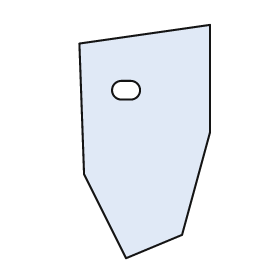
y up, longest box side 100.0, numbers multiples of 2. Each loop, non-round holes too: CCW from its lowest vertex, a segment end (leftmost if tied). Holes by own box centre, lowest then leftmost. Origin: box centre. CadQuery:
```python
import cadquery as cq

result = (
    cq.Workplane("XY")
    .moveTo(-8.0, -50.0)
    .lineTo(16.0, -40.0)
    .lineTo(28.0, 4.0)
    .lineTo(28.0, 50.0)
    .lineTo(-28.0, 42.0)
    .lineTo(-26.0, -14.0)
    .close()
    .moveTo(-10.0, 18.0)
    .lineTo(-6.0, 18.0)
    .threePointArc((-2.0, 22.0), (-6.0, 26.0))
    .lineTo(-10.0, 26.0)
    .threePointArc((-14.0, 22.0), (-10.0, 18.0))
    .close()
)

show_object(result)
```